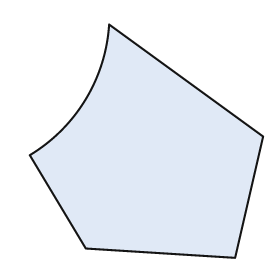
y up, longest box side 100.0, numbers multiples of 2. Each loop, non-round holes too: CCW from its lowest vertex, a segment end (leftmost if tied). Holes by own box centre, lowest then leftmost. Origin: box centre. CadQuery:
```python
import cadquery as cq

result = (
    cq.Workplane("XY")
    .moveTo(38.0, -50.0)
    .lineTo(50.0, 2.0)
    .lineTo(-16.0, 50.0)
    .threePointArc((-26.0, 18.0), (-50.0, -6.0))
    .lineTo(-26.0, -46.0)
    .close()
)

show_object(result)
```